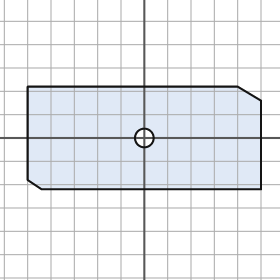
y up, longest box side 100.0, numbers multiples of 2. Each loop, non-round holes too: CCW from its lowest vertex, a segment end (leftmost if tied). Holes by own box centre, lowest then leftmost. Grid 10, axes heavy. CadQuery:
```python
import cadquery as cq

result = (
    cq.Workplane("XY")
    .moveTo(-44.0, -22.0)
    .lineTo(50.0, -22.0)
    .lineTo(50.0, 16.0)
    .lineTo(40.0, 22.0)
    .lineTo(-50.0, 22.0)
    .lineTo(-50.0, -18.0)
    .close()
    .moveTo(0.0, 0.0)
    .circle(4.0)
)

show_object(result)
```